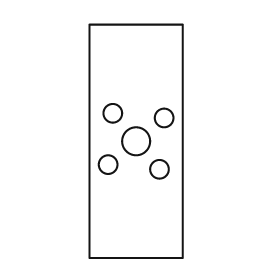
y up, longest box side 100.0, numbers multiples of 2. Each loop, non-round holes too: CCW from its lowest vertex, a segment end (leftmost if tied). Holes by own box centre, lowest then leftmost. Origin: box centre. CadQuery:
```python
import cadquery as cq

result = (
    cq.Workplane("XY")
    .moveTo(-20.0, -50.0)
    .lineTo(20.0, -50.0)
    .lineTo(20.0, 50.0)
    .lineTo(-20.0, 50.0)
    .close()
    .moveTo(10.0, -12.0)
    .circle(4.0)
    .moveTo(-12.0, -10.0)
    .circle(4.0)
    .moveTo(0.0, 0.0)
    .circle(6.0)
    .moveTo(12.0, 10.0)
    .circle(4.0)
    .moveTo(-10.0, 12.0)
    .circle(4.0)
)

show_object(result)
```